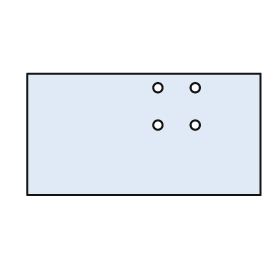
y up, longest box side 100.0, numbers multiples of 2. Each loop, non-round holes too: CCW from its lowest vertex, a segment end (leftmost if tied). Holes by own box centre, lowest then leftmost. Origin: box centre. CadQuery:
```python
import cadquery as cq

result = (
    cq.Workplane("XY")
    .moveTo(-50.0, -26.0)
    .lineTo(50.0, -26.0)
    .lineTo(50.0, 26.0)
    .lineTo(-50.0, 26.0)
    .close()
    .moveTo(6.0, 4.0)
    .circle(2.0)
    .moveTo(22.0, 4.0)
    .circle(2.0)
    .moveTo(6.0, 20.0)
    .circle(2.0)
    .moveTo(22.0, 20.0)
    .circle(2.0)
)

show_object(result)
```